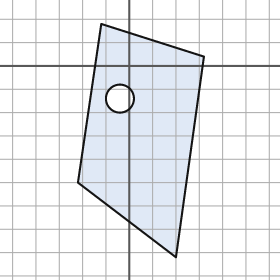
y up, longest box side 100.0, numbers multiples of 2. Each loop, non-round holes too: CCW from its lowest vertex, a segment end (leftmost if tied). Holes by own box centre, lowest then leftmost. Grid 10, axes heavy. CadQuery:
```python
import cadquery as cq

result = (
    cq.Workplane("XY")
    .moveTo(20.0, -82.0)
    .lineTo(32.0, 4.0)
    .lineTo(-12.0, 18.0)
    .lineTo(-22.0, -50.0)
    .close()
    .moveTo(-4.0, -14.0)
    .circle(6.0)
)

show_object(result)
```